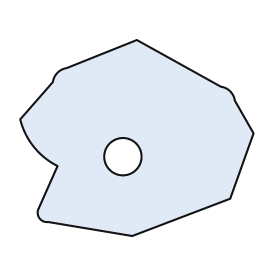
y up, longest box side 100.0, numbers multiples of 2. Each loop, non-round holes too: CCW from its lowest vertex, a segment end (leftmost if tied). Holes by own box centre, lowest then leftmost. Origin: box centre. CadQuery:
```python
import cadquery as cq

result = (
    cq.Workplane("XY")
    .moveTo(-2.0, -42.0)
    .lineTo(40.0, -26.0)
    .lineTo(50.0, 2.0)
    .lineTo(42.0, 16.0)
    .threePointArc((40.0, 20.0), (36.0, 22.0))
    .lineTo(0.0, 42.0)
    .lineTo(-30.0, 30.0)
    .threePointArc((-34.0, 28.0), (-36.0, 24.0))
    .lineTo(-50.0, 8.0)
    .threePointArc((-44.0, -4.0), (-34.0, -12.0))
    .lineTo(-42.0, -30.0)
    .threePointArc((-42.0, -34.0), (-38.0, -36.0))
    .close()
    .moveTo(-6.0, -8.0)
    .circle(8.0)
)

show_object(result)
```